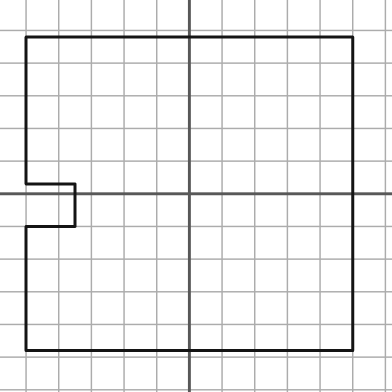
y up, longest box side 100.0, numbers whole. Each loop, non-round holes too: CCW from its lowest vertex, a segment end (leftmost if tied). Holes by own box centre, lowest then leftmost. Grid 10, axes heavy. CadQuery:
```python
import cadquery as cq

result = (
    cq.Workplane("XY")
    .moveTo(-50.0, -48.0)
    .lineTo(50.0, -48.0)
    .lineTo(50.0, 48.0)
    .lineTo(-50.0, 48.0)
    .lineTo(-50.0, 3.0)
    .lineTo(-35.0, 3.0)
    .lineTo(-35.0, -10.0)
    .lineTo(-50.0, -10.0)
    .close()
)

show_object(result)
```